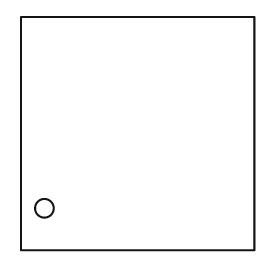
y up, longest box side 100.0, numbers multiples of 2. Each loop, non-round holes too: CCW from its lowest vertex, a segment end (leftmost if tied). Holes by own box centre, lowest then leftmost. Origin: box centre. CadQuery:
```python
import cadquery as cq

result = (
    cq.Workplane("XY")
    .moveTo(-50.0, -50.0)
    .lineTo(50.0, -50.0)
    .lineTo(50.0, 50.0)
    .lineTo(-50.0, 50.0)
    .close()
    .moveTo(-40.0, -32.0)
    .circle(4.0)
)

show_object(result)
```